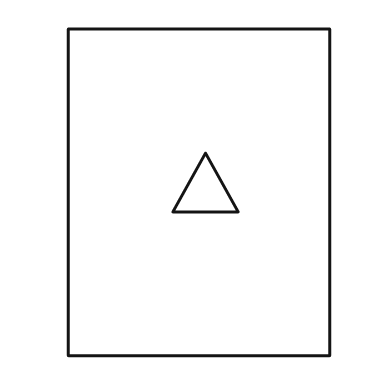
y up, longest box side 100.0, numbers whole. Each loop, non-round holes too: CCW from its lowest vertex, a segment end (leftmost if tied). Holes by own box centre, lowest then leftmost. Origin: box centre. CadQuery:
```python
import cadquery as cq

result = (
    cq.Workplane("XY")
    .moveTo(-40.0, -50.0)
    .lineTo(40.0, -50.0)
    .lineTo(40.0, 50.0)
    .lineTo(-40.0, 50.0)
    .close()
    .moveTo(-8.0, -6.0)
    .lineTo(12.0, -6.0)
    .lineTo(2.0, 12.0)
    .close()
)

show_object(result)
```